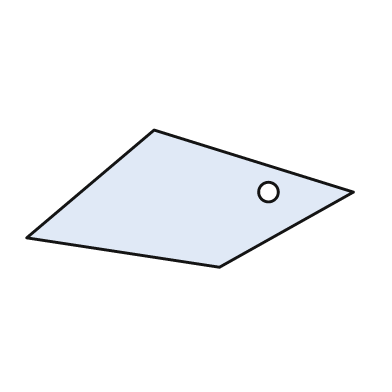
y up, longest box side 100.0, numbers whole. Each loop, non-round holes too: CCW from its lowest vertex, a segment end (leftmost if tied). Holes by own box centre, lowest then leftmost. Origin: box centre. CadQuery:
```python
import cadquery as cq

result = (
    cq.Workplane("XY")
    .moveTo(9.0, -21.0)
    .lineTo(50.0, 2.0)
    .lineTo(-11.0, 21.0)
    .lineTo(-50.0, -12.0)
    .close()
    .moveTo(24.0, 2.0)
    .circle(3.0)
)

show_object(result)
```